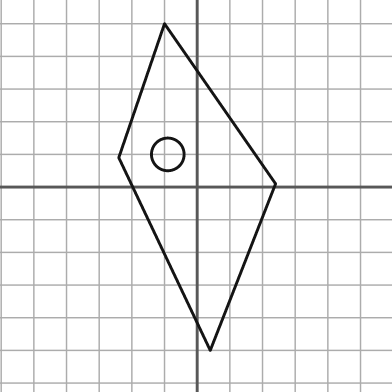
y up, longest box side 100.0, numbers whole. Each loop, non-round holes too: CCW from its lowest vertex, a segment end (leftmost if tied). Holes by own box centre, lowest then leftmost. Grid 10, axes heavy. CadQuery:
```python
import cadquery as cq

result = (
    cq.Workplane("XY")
    .moveTo(4.0, -50.0)
    .lineTo(24.0, 1.0)
    .lineTo(-10.0, 50.0)
    .lineTo(-24.0, 9.0)
    .close()
    .moveTo(-9.0, 10.0)
    .circle(5.0)
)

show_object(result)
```